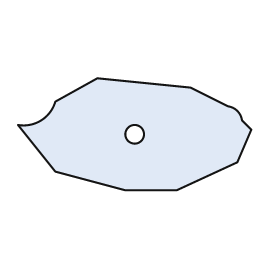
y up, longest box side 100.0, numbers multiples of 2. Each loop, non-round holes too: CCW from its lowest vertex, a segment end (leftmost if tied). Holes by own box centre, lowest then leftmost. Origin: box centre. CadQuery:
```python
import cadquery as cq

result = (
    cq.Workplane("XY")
    .moveTo(-4.0, -24.0)
    .lineTo(18.0, -24.0)
    .lineTo(44.0, -12.0)
    .lineTo(50.0, 2.0)
    .lineTo(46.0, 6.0)
    .threePointArc((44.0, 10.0), (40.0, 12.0))
    .lineTo(24.0, 20.0)
    .lineTo(-16.0, 24.0)
    .lineTo(-34.0, 14.0)
    .threePointArc((-40.0, 6.0), (-50.0, 4.0))
    .lineTo(-34.0, -16.0)
    .close()
    .moveTo(0.0, 0.0)
    .circle(4.0)
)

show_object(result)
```